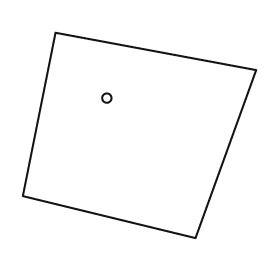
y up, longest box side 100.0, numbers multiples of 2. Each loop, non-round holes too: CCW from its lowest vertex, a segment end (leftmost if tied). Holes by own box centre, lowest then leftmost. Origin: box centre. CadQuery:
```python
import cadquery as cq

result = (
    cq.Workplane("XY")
    .moveTo(24.0, -44.0)
    .lineTo(50.0, 28.0)
    .lineTo(-36.0, 44.0)
    .lineTo(-50.0, -26.0)
    .close()
    .moveTo(-14.0, 16.0)
    .circle(2.0)
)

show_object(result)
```